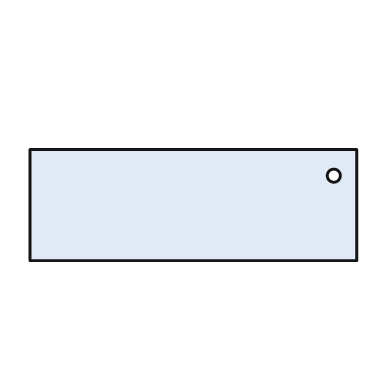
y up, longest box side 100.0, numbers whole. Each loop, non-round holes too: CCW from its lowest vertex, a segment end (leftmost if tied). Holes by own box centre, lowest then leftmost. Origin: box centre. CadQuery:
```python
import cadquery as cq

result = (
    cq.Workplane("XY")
    .moveTo(-50.0, -17.0)
    .lineTo(50.0, -17.0)
    .lineTo(50.0, 17.0)
    .lineTo(-50.0, 17.0)
    .close()
    .moveTo(43.0, 9.0)
    .circle(2.0)
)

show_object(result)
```